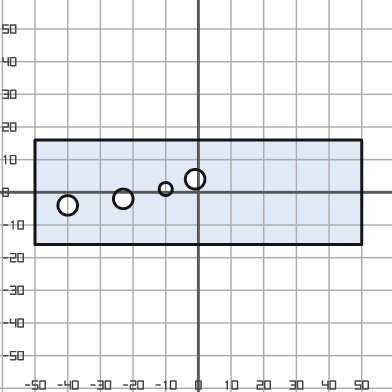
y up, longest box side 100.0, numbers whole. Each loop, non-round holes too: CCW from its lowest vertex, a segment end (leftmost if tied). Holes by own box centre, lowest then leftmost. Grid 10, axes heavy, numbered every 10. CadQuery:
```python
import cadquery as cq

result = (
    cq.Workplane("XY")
    .moveTo(-50.0, -16.0)
    .lineTo(50.0, -16.0)
    .lineTo(50.0, 16.0)
    .lineTo(-50.0, 16.0)
    .close()
    .moveTo(-40.0, -4.0)
    .circle(3.0)
    .moveTo(-23.0, -2.0)
    .circle(3.0)
    .moveTo(-10.0, 1.0)
    .circle(2.0)
    .moveTo(-1.0, 4.0)
    .circle(3.0)
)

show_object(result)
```